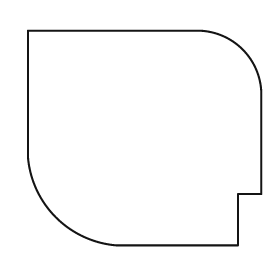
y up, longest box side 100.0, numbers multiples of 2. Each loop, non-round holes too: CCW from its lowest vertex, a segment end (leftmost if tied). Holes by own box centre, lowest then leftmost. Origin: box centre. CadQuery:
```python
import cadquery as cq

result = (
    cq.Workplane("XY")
    .moveTo(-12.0, -46.0)
    .lineTo(40.0, -46.0)
    .lineTo(40.0, -24.0)
    .lineTo(50.0, -24.0)
    .lineTo(50.0, 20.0)
    .threePointArc((42.0, 38.0), (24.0, 46.0))
    .lineTo(-50.0, 46.0)
    .lineTo(-50.0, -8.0)
    .threePointArc((-38.0, -34.0), (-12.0, -46.0))
    .close()
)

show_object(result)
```